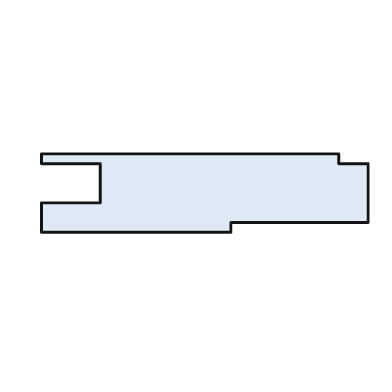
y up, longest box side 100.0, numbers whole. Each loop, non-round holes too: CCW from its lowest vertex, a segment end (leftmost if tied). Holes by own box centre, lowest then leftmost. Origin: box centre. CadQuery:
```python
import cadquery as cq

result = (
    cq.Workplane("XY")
    .moveTo(-50.0, -12.0)
    .lineTo(8.0, -12.0)
    .lineTo(8.0, -9.0)
    .lineTo(50.0, -9.0)
    .lineTo(50.0, 9.0)
    .lineTo(41.0, 9.0)
    .lineTo(41.0, 12.0)
    .lineTo(-50.0, 12.0)
    .lineTo(-50.0, 9.0)
    .lineTo(-32.0, 9.0)
    .lineTo(-32.0, -3.0)
    .lineTo(-50.0, -3.0)
    .close()
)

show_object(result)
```